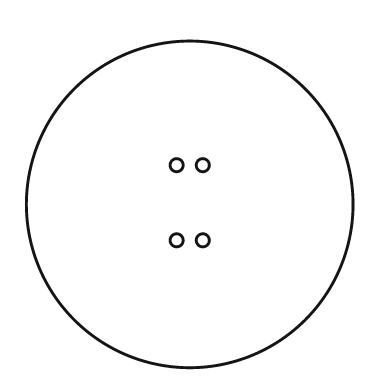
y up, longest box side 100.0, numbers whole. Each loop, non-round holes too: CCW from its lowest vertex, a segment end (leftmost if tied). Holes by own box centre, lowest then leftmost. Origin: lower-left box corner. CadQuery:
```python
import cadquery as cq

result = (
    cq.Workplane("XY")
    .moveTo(50.0, 50.0)
    .circle(50.0)
    .moveTo(46.0, 39.0)
    .circle(2.0)
    .moveTo(54.0, 39.0)
    .circle(2.0)
    .moveTo(46.0, 62.0)
    .circle(2.0)
    .moveTo(54.0, 62.0)
    .circle(2.0)
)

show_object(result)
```